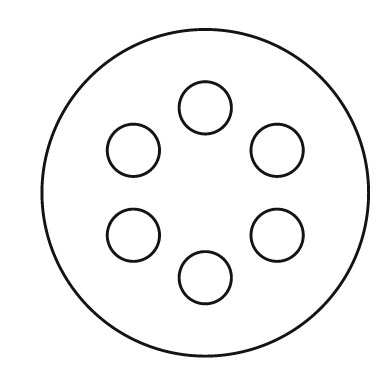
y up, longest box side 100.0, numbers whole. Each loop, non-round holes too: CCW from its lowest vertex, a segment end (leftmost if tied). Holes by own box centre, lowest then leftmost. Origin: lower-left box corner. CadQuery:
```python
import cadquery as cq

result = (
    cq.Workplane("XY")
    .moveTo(50.0, 50.0)
    .circle(50.0)
    .moveTo(50.0, 24.0)
    .circle(8.0)
    .moveTo(28.0, 37.0)
    .circle(8.0)
    .moveTo(72.0, 37.0)
    .circle(8.0)
    .moveTo(28.0, 63.0)
    .circle(8.0)
    .moveTo(72.0, 63.0)
    .circle(8.0)
    .moveTo(50.0, 76.0)
    .circle(8.0)
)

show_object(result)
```